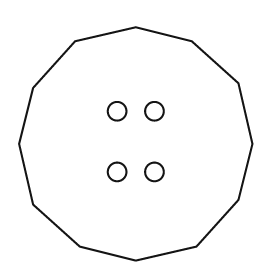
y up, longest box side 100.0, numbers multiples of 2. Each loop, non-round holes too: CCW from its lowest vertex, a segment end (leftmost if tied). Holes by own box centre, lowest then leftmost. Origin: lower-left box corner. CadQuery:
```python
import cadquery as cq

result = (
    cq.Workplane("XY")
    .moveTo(50.0, 0.0)
    .lineTo(76.0, 6.0)
    .lineTo(94.0, 26.0)
    .lineTo(100.0, 50.0)
    .lineTo(94.0, 76.0)
    .lineTo(74.0, 94.0)
    .lineTo(50.0, 100.0)
    .lineTo(24.0, 94.0)
    .lineTo(6.0, 74.0)
    .lineTo(0.0, 50.0)
    .lineTo(6.0, 24.0)
    .lineTo(26.0, 6.0)
    .close()
    .moveTo(42.0, 38.0)
    .circle(4.0)
    .moveTo(58.0, 38.0)
    .circle(4.0)
    .moveTo(42.0, 64.0)
    .circle(4.0)
    .moveTo(58.0, 64.0)
    .circle(4.0)
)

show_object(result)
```